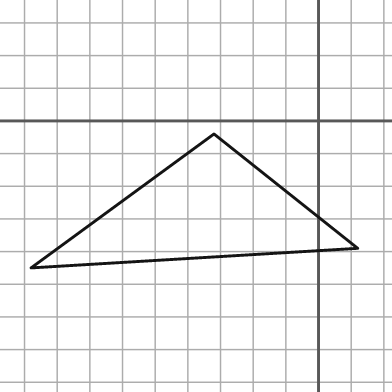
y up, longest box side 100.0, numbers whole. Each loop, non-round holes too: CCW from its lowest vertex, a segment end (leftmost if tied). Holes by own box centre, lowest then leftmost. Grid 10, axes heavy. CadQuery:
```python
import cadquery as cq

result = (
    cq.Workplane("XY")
    .moveTo(-88.0, -45.0)
    .lineTo(12.0, -39.0)
    .lineTo(-32.0, -4.0)
    .close()
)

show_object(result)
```